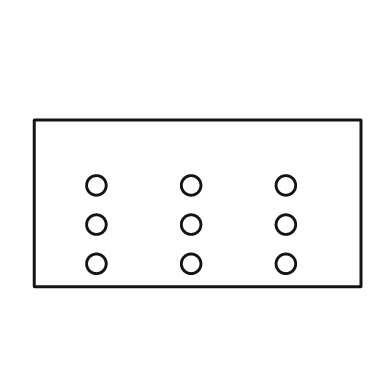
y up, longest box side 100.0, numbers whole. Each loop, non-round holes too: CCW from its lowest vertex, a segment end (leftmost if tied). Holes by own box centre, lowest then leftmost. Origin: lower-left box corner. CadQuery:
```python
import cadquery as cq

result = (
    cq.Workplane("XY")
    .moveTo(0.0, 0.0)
    .lineTo(100.0, 0.0)
    .lineTo(100.0, 51.0)
    .lineTo(0.0, 51.0)
    .close()
    .moveTo(19.0, 7.0)
    .circle(3.0)
    .moveTo(48.0, 7.0)
    .circle(3.0)
    .moveTo(77.0, 7.0)
    .circle(3.0)
    .moveTo(19.0, 19.0)
    .circle(3.0)
    .moveTo(48.0, 19.0)
    .circle(3.0)
    .moveTo(77.0, 19.0)
    .circle(3.0)
    .moveTo(19.0, 31.0)
    .circle(3.0)
    .moveTo(48.0, 31.0)
    .circle(3.0)
    .moveTo(77.0, 31.0)
    .circle(3.0)
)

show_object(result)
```